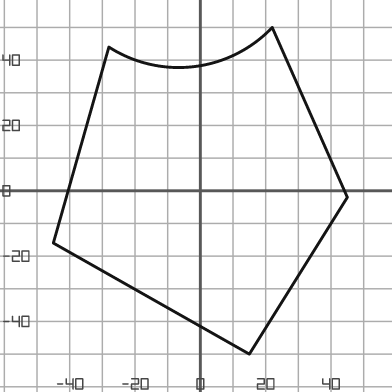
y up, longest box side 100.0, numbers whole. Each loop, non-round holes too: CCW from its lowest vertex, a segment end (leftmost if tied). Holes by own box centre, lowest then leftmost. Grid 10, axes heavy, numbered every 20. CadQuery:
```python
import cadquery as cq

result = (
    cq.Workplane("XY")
    .moveTo(15.0, -50.0)
    .lineTo(45.0, -2.0)
    .lineTo(22.0, 50.0)
    .threePointArc((-2.0, 38.0), (-28.0, 44.0))
    .lineTo(-45.0, -16.0)
    .close()
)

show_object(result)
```